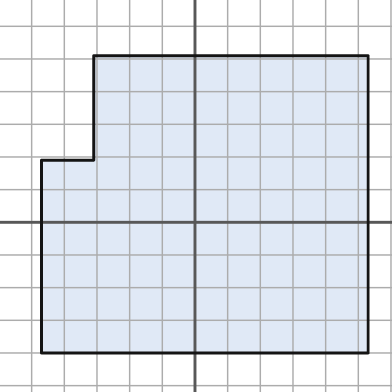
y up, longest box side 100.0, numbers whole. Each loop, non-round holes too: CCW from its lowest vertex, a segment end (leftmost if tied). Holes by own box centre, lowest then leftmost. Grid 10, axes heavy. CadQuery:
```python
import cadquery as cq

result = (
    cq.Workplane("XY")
    .moveTo(-47.0, -40.0)
    .lineTo(53.0, -40.0)
    .lineTo(53.0, 51.0)
    .lineTo(-31.0, 51.0)
    .lineTo(-31.0, 19.0)
    .lineTo(-47.0, 19.0)
    .close()
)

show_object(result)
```